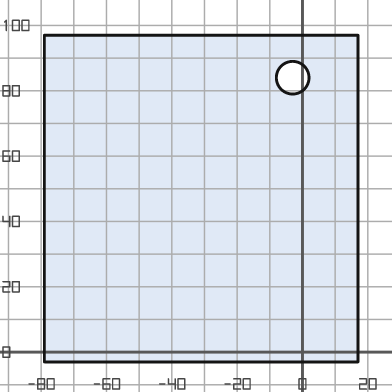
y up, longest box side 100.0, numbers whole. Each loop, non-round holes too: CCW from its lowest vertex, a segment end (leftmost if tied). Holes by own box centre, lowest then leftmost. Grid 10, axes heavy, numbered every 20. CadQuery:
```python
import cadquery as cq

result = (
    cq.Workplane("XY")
    .moveTo(-79.0, -3.0)
    .lineTo(17.0, -3.0)
    .lineTo(17.0, 97.0)
    .lineTo(-79.0, 97.0)
    .close()
    .moveTo(-3.0, 84.0)
    .circle(5.0)
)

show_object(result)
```